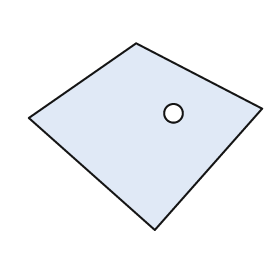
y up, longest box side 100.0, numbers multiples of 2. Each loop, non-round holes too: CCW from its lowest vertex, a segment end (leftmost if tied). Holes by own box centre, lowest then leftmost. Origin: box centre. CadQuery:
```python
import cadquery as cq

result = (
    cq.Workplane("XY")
    .moveTo(4.0, -40.0)
    .lineTo(50.0, 12.0)
    .lineTo(-4.0, 40.0)
    .lineTo(-50.0, 8.0)
    .close()
    .moveTo(12.0, 10.0)
    .circle(4.0)
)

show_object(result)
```